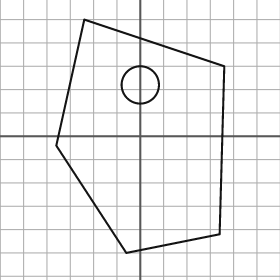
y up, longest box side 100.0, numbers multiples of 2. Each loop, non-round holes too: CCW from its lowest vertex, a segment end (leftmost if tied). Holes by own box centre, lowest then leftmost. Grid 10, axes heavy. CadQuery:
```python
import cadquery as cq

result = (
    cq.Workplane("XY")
    .moveTo(-6.0, -50.0)
    .lineTo(34.0, -42.0)
    .lineTo(36.0, 30.0)
    .lineTo(-24.0, 50.0)
    .lineTo(-36.0, -4.0)
    .close()
    .moveTo(0.0, 22.0)
    .circle(8.0)
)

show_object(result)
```